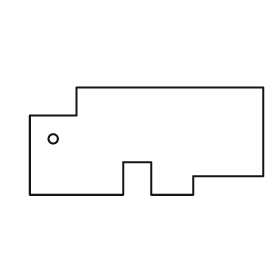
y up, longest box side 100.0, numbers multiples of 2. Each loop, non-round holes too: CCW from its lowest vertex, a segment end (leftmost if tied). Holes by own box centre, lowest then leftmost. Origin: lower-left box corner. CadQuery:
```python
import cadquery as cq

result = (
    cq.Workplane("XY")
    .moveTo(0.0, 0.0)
    .lineTo(40.0, 0.0)
    .lineTo(40.0, 14.0)
    .lineTo(52.0, 14.0)
    .lineTo(52.0, 0.0)
    .lineTo(70.0, 0.0)
    .lineTo(70.0, 8.0)
    .lineTo(100.0, 8.0)
    .lineTo(100.0, 46.0)
    .lineTo(20.0, 46.0)
    .lineTo(20.0, 34.0)
    .lineTo(0.0, 34.0)
    .close()
    .moveTo(10.0, 24.0)
    .circle(2.0)
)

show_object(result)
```